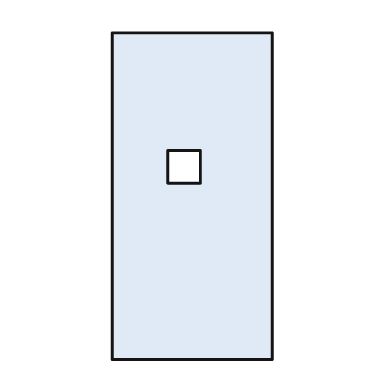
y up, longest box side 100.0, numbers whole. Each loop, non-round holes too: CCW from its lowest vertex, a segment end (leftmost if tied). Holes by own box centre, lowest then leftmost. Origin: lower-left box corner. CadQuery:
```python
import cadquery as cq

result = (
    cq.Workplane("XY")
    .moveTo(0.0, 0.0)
    .lineTo(49.0, 0.0)
    .lineTo(49.0, 100.0)
    .lineTo(0.0, 100.0)
    .close()
    .moveTo(17.0, 54.0)
    .lineTo(27.0, 54.0)
    .lineTo(27.0, 64.0)
    .lineTo(17.0, 64.0)
    .close()
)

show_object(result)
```